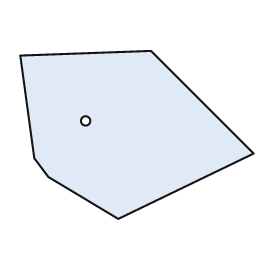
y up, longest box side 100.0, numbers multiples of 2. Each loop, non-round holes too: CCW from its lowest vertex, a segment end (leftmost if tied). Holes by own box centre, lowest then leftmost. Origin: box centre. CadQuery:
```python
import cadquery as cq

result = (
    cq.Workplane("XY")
    .moveTo(-8.0, -36.0)
    .lineTo(50.0, -8.0)
    .lineTo(6.0, 36.0)
    .lineTo(-50.0, 34.0)
    .lineTo(-44.0, -10.0)
    .lineTo(-38.0, -18.0)
    .close()
    .moveTo(-22.0, 6.0)
    .circle(2.0)
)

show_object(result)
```